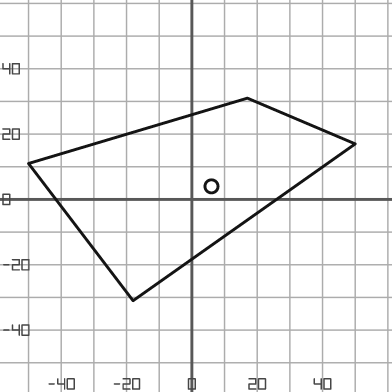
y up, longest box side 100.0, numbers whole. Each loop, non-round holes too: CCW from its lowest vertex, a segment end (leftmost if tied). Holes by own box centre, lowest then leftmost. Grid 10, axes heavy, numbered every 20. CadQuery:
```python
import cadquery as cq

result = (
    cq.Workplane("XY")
    .moveTo(-18.0, -31.0)
    .lineTo(50.0, 17.0)
    .lineTo(17.0, 31.0)
    .lineTo(-50.0, 11.0)
    .close()
    .moveTo(6.0, 4.0)
    .circle(2.0)
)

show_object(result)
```